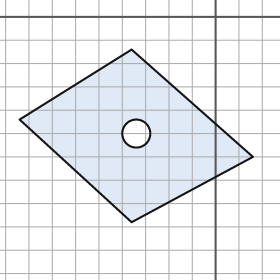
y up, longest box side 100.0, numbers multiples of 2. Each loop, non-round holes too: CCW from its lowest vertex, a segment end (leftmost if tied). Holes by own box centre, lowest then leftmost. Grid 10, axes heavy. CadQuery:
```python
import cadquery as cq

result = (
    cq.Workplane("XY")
    .moveTo(-36.0, -88.0)
    .lineTo(16.0, -60.0)
    .lineTo(-36.0, -14.0)
    .lineTo(-84.0, -44.0)
    .close()
    .moveTo(-34.0, -50.0)
    .circle(6.0)
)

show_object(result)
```